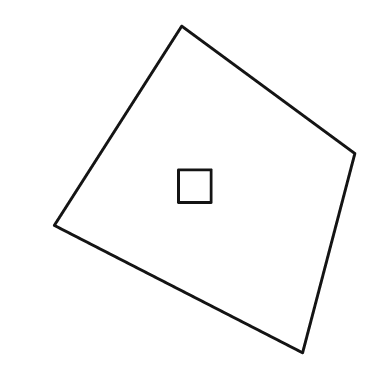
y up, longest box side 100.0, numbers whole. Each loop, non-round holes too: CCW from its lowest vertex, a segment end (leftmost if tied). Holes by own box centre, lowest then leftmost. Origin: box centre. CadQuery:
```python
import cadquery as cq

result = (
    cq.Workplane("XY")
    .moveTo(30.0, -50.0)
    .lineTo(46.0, 11.0)
    .lineTo(-7.0, 50.0)
    .lineTo(-46.0, -11.0)
    .close()
    .moveTo(-8.0, -4.0)
    .lineTo(2.0, -4.0)
    .lineTo(2.0, 6.0)
    .lineTo(-8.0, 6.0)
    .close()
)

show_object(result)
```